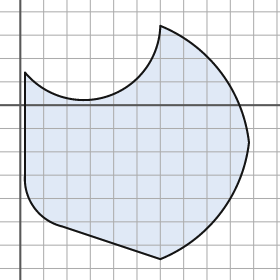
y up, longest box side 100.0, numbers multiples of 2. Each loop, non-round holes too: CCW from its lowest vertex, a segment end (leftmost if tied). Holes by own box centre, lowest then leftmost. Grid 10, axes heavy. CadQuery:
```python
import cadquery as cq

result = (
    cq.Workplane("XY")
    .moveTo(60.0, -66.0)
    .threePointArc((86.0, -46.0), (98.0, -16.0))
    .threePointArc((86.0, 14.0), (60.0, 34.0))
    .threePointArc((38.0, 4.0), (2.0, 14.0))
    .lineTo(2.0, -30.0)
    .threePointArc((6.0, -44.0), (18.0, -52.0))
    .close()
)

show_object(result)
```